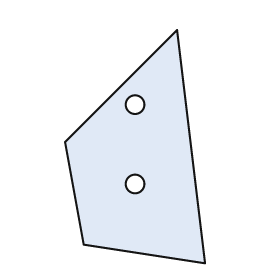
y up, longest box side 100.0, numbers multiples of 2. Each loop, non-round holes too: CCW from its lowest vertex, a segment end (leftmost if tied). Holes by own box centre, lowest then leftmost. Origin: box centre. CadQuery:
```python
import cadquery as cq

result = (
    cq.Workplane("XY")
    .moveTo(30.0, -50.0)
    .lineTo(18.0, 50.0)
    .lineTo(-30.0, 2.0)
    .lineTo(-22.0, -42.0)
    .close()
    .moveTo(0.0, -16.0)
    .circle(4.0)
    .moveTo(0.0, 18.0)
    .circle(4.0)
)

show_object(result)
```